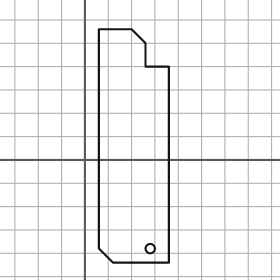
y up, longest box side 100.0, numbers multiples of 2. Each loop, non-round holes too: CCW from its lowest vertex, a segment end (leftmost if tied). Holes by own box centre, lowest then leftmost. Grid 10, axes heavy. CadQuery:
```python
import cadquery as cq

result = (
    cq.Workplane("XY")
    .moveTo(12.0, -44.0)
    .lineTo(36.0, -44.0)
    .lineTo(36.0, 40.0)
    .lineTo(26.0, 40.0)
    .lineTo(26.0, 50.0)
    .lineTo(20.0, 56.0)
    .lineTo(6.0, 56.0)
    .lineTo(6.0, -38.0)
    .close()
    .moveTo(28.0, -38.0)
    .circle(2.0)
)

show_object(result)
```